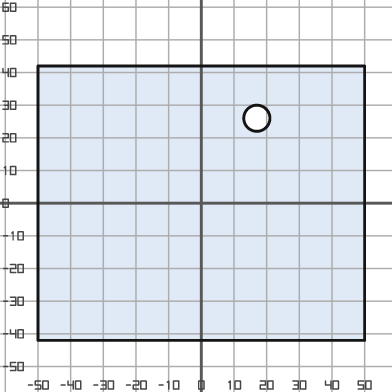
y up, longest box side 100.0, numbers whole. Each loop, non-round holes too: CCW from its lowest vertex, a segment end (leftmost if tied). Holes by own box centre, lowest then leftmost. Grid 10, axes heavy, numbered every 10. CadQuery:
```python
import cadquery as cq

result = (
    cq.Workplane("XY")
    .moveTo(-50.0, -42.0)
    .lineTo(50.0, -42.0)
    .lineTo(50.0, 42.0)
    .lineTo(-50.0, 42.0)
    .close()
    .moveTo(17.0, 26.0)
    .circle(4.0)
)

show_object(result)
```